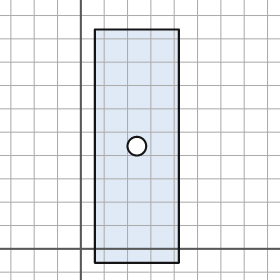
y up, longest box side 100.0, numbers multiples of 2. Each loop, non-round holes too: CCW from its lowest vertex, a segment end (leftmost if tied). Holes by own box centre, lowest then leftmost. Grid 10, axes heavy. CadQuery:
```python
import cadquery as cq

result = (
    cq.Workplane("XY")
    .moveTo(6.0, -6.0)
    .lineTo(42.0, -6.0)
    .lineTo(42.0, 94.0)
    .lineTo(6.0, 94.0)
    .close()
    .moveTo(24.0, 44.0)
    .circle(4.0)
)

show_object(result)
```